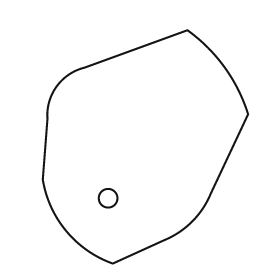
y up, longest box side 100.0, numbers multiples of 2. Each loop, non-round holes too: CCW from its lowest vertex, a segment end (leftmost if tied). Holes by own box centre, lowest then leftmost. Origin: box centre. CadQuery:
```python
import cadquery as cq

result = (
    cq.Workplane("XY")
    .moveTo(-14.0, -50.0)
    .lineTo(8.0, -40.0)
    .threePointArc((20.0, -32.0), (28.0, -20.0))
    .lineTo(44.0, 14.0)
    .threePointArc((34.0, 34.0), (18.0, 50.0))
    .lineTo(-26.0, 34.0)
    .threePointArc((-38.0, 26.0), (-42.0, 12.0))
    .lineTo(-44.0, -14.0)
    .threePointArc((-34.0, -36.0), (-14.0, -50.0))
    .close()
    .moveTo(-16.0, -22.0)
    .circle(4.0)
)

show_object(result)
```